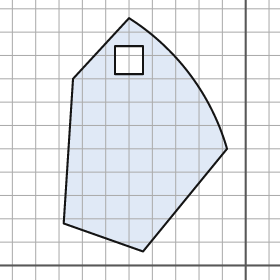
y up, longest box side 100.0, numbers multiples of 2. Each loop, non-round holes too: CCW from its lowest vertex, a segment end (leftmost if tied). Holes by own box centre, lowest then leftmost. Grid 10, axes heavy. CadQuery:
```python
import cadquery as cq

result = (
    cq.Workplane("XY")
    .moveTo(-44.0, 6.0)
    .lineTo(-8.0, 50.0)
    .threePointArc((-24.0, 82.0), (-50.0, 106.0))
    .lineTo(-74.0, 80.0)
    .lineTo(-78.0, 18.0)
    .close()
    .moveTo(-56.0, 82.0)
    .lineTo(-44.0, 82.0)
    .lineTo(-44.0, 94.0)
    .lineTo(-56.0, 94.0)
    .close()
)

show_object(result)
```